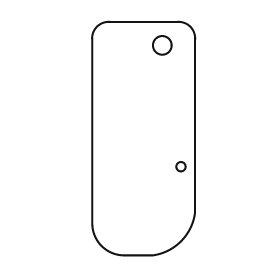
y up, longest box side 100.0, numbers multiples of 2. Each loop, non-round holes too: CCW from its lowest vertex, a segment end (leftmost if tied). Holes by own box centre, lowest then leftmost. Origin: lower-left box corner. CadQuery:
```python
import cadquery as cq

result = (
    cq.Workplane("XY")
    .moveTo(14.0, 0.0)
    .lineTo(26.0, 0.0)
    .threePointArc((38.0, 6.0), (44.0, 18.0))
    .lineTo(44.0, 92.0)
    .threePointArc((42.0, 98.0), (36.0, 100.0))
    .lineTo(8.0, 100.0)
    .threePointArc((2.0, 98.0), (0.0, 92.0))
    .lineTo(0.0, 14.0)
    .threePointArc((4.0, 4.0), (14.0, 0.0))
    .close()
    .moveTo(38.0, 38.0)
    .circle(2.0)
    .moveTo(30.0, 90.0)
    .circle(4.0)
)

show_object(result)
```